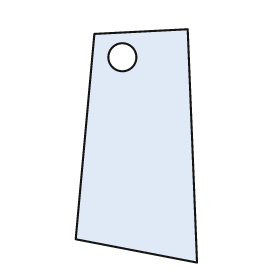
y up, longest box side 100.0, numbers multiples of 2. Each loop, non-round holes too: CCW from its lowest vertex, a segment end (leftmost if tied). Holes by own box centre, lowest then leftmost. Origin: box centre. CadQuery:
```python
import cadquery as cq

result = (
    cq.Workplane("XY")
    .moveTo(26.0, -50.0)
    .lineTo(22.0, 50.0)
    .lineTo(-18.0, 48.0)
    .lineTo(-26.0, -40.0)
    .close()
    .moveTo(-6.0, 38.0)
    .circle(6.0)
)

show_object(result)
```